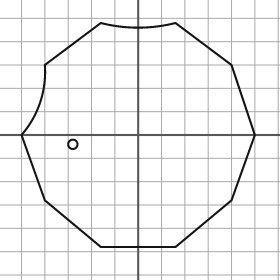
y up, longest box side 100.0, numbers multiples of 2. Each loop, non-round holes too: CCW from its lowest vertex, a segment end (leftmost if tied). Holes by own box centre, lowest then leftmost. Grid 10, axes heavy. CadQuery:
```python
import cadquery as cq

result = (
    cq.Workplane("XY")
    .moveTo(-16.0, -48.0)
    .lineTo(16.0, -48.0)
    .lineTo(40.0, -28.0)
    .lineTo(50.0, 0.0)
    .lineTo(40.0, 30.0)
    .lineTo(16.0, 48.0)
    .threePointArc((0.0, 46.0), (-16.0, 48.0))
    .lineTo(-40.0, 30.0)
    .threePointArc((-42.0, 14.0), (-50.0, 0.0))
    .lineTo(-40.0, -28.0)
    .close()
    .moveTo(-28.0, -4.0)
    .circle(2.0)
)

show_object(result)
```